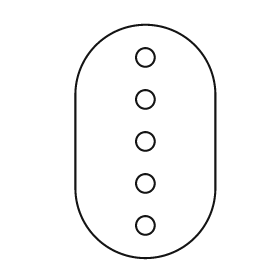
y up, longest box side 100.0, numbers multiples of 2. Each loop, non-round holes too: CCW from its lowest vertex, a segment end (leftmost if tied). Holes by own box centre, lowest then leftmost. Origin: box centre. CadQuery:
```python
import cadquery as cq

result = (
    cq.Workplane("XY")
    .moveTo(-30.0, -20.0)
    .threePointArc((0.0, -50.0), (30.0, -20.0))
    .lineTo(30.0, 20.0)
    .threePointArc((0.0, 50.0), (-30.0, 20.0))
    .close()
    .moveTo(0.0, -36.0)
    .circle(4.0)
    .moveTo(0.0, -18.0)
    .circle(4.0)
    .moveTo(0.0, 0.0)
    .circle(4.0)
    .moveTo(0.0, 18.0)
    .circle(4.0)
    .moveTo(0.0, 36.0)
    .circle(4.0)
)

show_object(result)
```